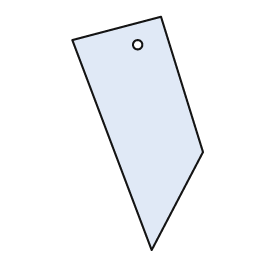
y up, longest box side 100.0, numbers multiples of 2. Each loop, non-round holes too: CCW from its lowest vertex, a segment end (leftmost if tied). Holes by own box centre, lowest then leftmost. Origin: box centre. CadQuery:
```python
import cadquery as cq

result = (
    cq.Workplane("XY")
    .moveTo(6.0, -50.0)
    .lineTo(28.0, -8.0)
    .lineTo(10.0, 50.0)
    .lineTo(-28.0, 40.0)
    .close()
    .moveTo(0.0, 38.0)
    .circle(2.0)
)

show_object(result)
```